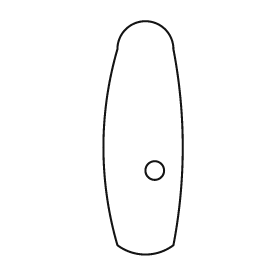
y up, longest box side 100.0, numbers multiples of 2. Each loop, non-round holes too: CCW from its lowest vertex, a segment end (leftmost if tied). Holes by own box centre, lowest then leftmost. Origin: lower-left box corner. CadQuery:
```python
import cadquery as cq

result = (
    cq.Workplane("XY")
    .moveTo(6.0, 4.0)
    .threePointArc((18.0, 0.0), (30.0, 4.0))
    .threePointArc((34.0, 46.0), (30.0, 88.0))
    .threePointArc((18.0, 100.0), (6.0, 88.0))
    .threePointArc((0.0, 46.0), (6.0, 4.0))
    .close()
    .moveTo(22.0, 36.0)
    .circle(4.0)
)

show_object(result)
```